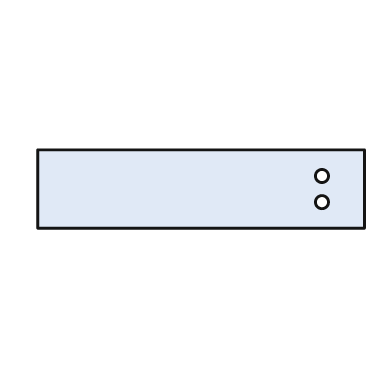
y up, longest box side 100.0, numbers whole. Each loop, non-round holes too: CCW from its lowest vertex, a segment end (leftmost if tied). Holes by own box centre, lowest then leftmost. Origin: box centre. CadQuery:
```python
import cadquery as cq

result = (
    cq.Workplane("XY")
    .moveTo(-50.0, -12.0)
    .lineTo(50.0, -12.0)
    .lineTo(50.0, 12.0)
    .lineTo(-50.0, 12.0)
    .close()
    .moveTo(37.0, -4.0)
    .circle(2.0)
    .moveTo(37.0, 4.0)
    .circle(2.0)
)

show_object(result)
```